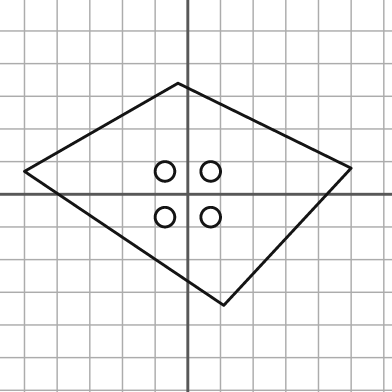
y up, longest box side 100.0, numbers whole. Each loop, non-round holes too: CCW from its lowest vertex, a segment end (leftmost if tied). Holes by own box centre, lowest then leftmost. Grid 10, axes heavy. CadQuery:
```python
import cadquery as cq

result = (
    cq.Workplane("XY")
    .moveTo(11.0, -34.0)
    .lineTo(50.0, 8.0)
    .lineTo(-3.0, 34.0)
    .lineTo(-50.0, 7.0)
    .close()
    .moveTo(-7.0, -7.0)
    .circle(3.0)
    .moveTo(7.0, -7.0)
    .circle(3.0)
    .moveTo(-7.0, 7.0)
    .circle(3.0)
    .moveTo(7.0, 7.0)
    .circle(3.0)
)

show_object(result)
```